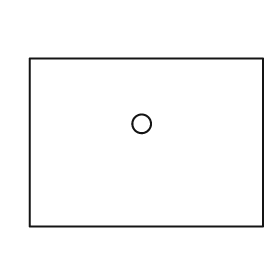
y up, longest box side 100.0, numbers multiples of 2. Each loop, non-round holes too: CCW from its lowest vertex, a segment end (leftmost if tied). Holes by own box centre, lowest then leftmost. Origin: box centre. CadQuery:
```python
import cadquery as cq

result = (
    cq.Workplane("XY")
    .moveTo(-50.0, -36.0)
    .lineTo(50.0, -36.0)
    .lineTo(50.0, 36.0)
    .lineTo(-50.0, 36.0)
    .close()
    .moveTo(-2.0, 8.0)
    .circle(4.0)
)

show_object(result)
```